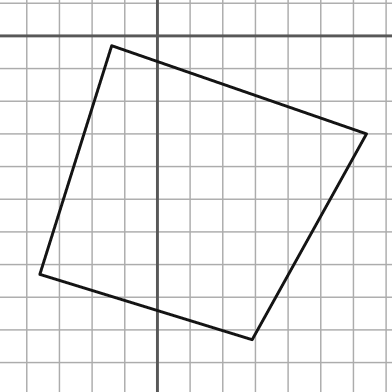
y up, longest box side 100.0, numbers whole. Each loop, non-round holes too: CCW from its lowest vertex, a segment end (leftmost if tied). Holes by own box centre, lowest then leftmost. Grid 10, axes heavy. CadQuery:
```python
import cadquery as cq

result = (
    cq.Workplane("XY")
    .moveTo(29.0, -93.0)
    .lineTo(64.0, -30.0)
    .lineTo(-14.0, -3.0)
    .lineTo(-36.0, -73.0)
    .close()
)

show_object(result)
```